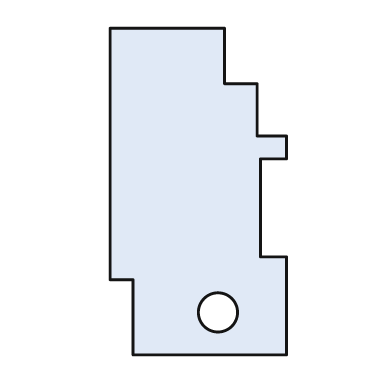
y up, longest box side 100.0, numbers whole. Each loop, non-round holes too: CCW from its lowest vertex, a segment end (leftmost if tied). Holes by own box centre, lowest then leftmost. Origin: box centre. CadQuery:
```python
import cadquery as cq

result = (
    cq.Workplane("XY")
    .moveTo(-20.0, -50.0)
    .lineTo(27.0, -50.0)
    .lineTo(27.0, -20.0)
    .lineTo(19.0, -20.0)
    .lineTo(19.0, 10.0)
    .lineTo(27.0, 10.0)
    .lineTo(27.0, 17.0)
    .lineTo(18.0, 17.0)
    .lineTo(18.0, 33.0)
    .lineTo(8.0, 33.0)
    .lineTo(8.0, 50.0)
    .lineTo(-27.0, 50.0)
    .lineTo(-27.0, -27.0)
    .lineTo(-20.0, -27.0)
    .close()
    .moveTo(6.0, -37.0)
    .circle(6.0)
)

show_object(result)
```